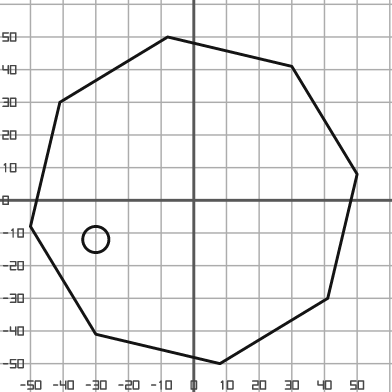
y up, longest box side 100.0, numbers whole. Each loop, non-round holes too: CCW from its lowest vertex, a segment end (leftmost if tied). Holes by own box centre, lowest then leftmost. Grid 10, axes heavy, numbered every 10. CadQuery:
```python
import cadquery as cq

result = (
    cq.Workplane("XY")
    .moveTo(8.0, -50.0)
    .lineTo(41.0, -30.0)
    .lineTo(50.0, 8.0)
    .lineTo(30.0, 41.0)
    .lineTo(-8.0, 50.0)
    .lineTo(-41.0, 30.0)
    .lineTo(-50.0, -8.0)
    .lineTo(-30.0, -41.0)
    .close()
    .moveTo(-30.0, -12.0)
    .circle(4.0)
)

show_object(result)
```